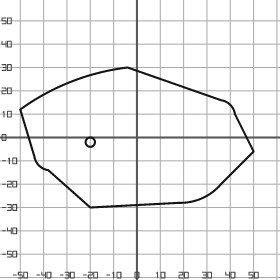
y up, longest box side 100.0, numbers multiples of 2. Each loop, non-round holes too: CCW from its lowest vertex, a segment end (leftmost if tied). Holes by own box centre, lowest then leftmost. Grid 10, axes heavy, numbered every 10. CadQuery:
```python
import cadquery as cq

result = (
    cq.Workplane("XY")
    .moveTo(-20.0, -30.0)
    .lineTo(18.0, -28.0)
    .threePointArc((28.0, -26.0), (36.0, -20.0))
    .lineTo(50.0, -6.0)
    .lineTo(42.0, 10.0)
    .threePointArc((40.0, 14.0), (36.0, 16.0))
    .lineTo(-4.0, 30.0)
    .threePointArc((-28.0, 24.0), (-50.0, 12.0))
    .lineTo(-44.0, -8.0)
    .threePointArc((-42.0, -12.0), (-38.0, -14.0))
    .close()
    .moveTo(-20.0, -2.0)
    .circle(2.0)
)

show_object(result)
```